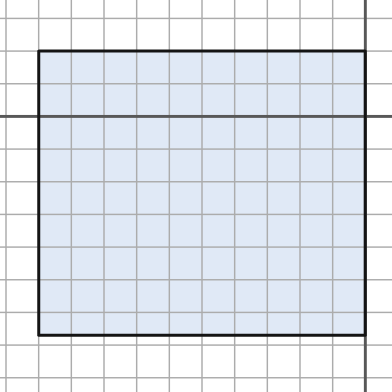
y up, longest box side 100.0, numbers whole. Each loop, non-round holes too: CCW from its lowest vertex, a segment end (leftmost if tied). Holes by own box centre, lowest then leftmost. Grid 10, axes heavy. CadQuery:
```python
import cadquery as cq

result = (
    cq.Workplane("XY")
    .moveTo(-100.0, -67.0)
    .lineTo(0.0, -67.0)
    .lineTo(0.0, 20.0)
    .lineTo(-100.0, 20.0)
    .close()
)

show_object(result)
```